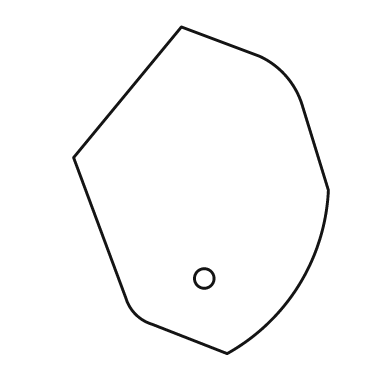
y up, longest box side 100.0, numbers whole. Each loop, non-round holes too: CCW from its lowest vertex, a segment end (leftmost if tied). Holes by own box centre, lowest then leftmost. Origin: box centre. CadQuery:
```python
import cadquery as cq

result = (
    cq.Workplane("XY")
    .moveTo(8.0, -50.0)
    .threePointArc((30.0, -29.0), (39.0, 0.0))
    .lineTo(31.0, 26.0)
    .threePointArc((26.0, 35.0), (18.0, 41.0))
    .lineTo(-6.0, 50.0)
    .lineTo(-39.0, 10.0)
    .lineTo(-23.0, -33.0)
    .threePointArc((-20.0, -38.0), (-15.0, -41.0))
    .close()
    .moveTo(1.0, -27.0)
    .circle(3.0)
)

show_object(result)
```